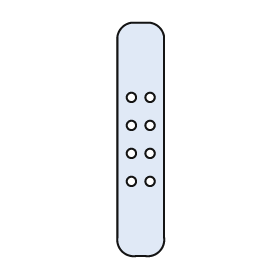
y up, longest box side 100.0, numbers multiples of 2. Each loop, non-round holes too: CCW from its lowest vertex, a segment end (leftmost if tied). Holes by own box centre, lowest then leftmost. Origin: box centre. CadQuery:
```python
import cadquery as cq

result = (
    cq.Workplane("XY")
    .moveTo(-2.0, -50.0)
    .lineTo(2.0, -50.0)
    .threePointArc((8.0, -48.0), (10.0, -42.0))
    .lineTo(10.0, 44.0)
    .threePointArc((8.0, 48.0), (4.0, 50.0))
    .lineTo(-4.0, 50.0)
    .threePointArc((-8.0, 48.0), (-10.0, 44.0))
    .lineTo(-10.0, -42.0)
    .threePointArc((-8.0, -48.0), (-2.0, -50.0))
    .close()
    .moveTo(-4.0, -18.0)
    .circle(2.0)
    .moveTo(4.0, -18.0)
    .circle(2.0)
    .moveTo(-4.0, -6.0)
    .circle(2.0)
    .moveTo(4.0, -6.0)
    .circle(2.0)
    .moveTo(-4.0, 6.0)
    .circle(2.0)
    .moveTo(4.0, 6.0)
    .circle(2.0)
    .moveTo(-4.0, 18.0)
    .circle(2.0)
    .moveTo(4.0, 18.0)
    .circle(2.0)
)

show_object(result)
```